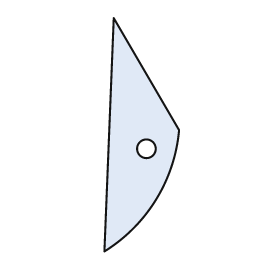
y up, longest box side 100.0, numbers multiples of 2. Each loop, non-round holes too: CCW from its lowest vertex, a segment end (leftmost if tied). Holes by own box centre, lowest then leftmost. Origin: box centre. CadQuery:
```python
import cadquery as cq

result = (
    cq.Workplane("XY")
    .moveTo(-16.0, -50.0)
    .threePointArc((6.0, -28.0), (16.0, 2.0))
    .lineTo(-12.0, 50.0)
    .close()
    .moveTo(2.0, -6.0)
    .circle(4.0)
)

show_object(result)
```